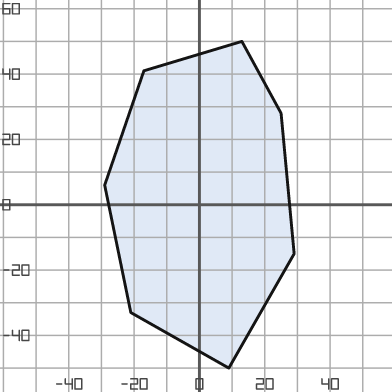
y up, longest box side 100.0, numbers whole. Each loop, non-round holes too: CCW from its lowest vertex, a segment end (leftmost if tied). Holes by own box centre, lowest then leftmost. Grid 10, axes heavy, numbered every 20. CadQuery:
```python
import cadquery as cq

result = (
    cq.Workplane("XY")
    .moveTo(9.0, -50.0)
    .lineTo(29.0, -15.0)
    .lineTo(25.0, 28.0)
    .lineTo(13.0, 50.0)
    .lineTo(-17.0, 41.0)
    .lineTo(-29.0, 6.0)
    .lineTo(-21.0, -33.0)
    .close()
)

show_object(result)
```